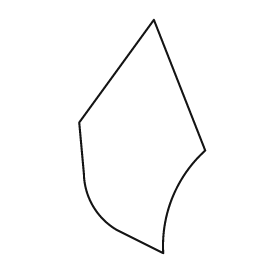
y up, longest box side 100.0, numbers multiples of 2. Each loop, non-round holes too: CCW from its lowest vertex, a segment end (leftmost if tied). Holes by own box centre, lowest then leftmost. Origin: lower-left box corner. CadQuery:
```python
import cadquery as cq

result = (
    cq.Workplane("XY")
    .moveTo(36.0, 0.0)
    .threePointArc((40.0, 24.0), (54.0, 44.0))
    .lineTo(32.0, 100.0)
    .lineTo(0.0, 56.0)
    .lineTo(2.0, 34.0)
    .threePointArc((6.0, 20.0), (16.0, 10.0))
    .close()
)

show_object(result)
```